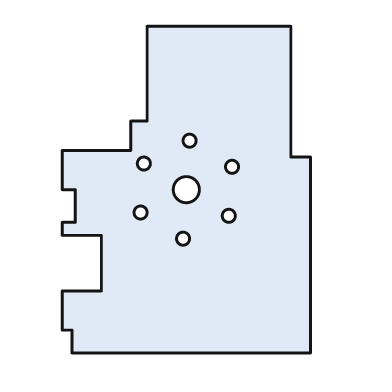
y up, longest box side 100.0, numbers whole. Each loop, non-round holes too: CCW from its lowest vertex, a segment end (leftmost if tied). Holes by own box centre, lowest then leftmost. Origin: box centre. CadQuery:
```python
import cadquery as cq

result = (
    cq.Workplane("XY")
    .moveTo(-35.0, -50.0)
    .lineTo(38.0, -50.0)
    .lineTo(38.0, 10.0)
    .lineTo(32.0, 10.0)
    .lineTo(32.0, 50.0)
    .lineTo(-12.0, 50.0)
    .lineTo(-12.0, 21.0)
    .lineTo(-17.0, 21.0)
    .lineTo(-17.0, 12.0)
    .lineTo(-38.0, 12.0)
    .lineTo(-38.0, 0.0)
    .lineTo(-34.0, 0.0)
    .lineTo(-34.0, -10.0)
    .lineTo(-38.0, -10.0)
    .lineTo(-38.0, -14.0)
    .lineTo(-26.0, -14.0)
    .lineTo(-26.0, -31.0)
    .lineTo(-38.0, -31.0)
    .lineTo(-38.0, -43.0)
    .lineTo(-35.0, -43.0)
    .close()
    .moveTo(-1.0, -15.0)
    .circle(2.0)
    .moveTo(13.0, -8.0)
    .circle(2.0)
    .moveTo(-14.0, -7.0)
    .circle(2.0)
    .moveTo(0.0, 0.0)
    .circle(4.0)
    .moveTo(14.0, 7.0)
    .circle(2.0)
    .moveTo(-13.0, 8.0)
    .circle(2.0)
    .moveTo(1.0, 15.0)
    .circle(2.0)
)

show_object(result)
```